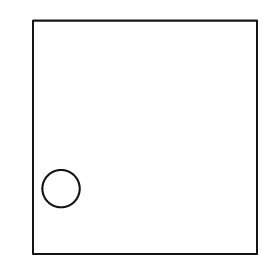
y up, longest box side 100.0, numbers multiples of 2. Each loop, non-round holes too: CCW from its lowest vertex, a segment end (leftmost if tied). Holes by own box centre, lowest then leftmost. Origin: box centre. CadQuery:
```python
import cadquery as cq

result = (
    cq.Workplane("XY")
    .moveTo(-48.0, -50.0)
    .lineTo(48.0, -50.0)
    .lineTo(48.0, 50.0)
    .lineTo(-48.0, 50.0)
    .close()
    .moveTo(-36.0, -22.0)
    .circle(8.0)
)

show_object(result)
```